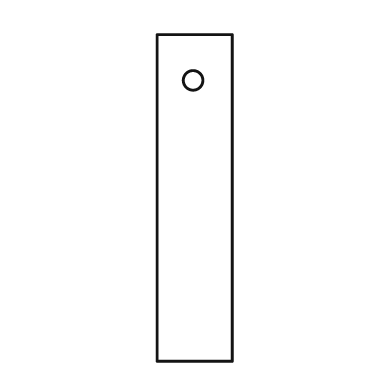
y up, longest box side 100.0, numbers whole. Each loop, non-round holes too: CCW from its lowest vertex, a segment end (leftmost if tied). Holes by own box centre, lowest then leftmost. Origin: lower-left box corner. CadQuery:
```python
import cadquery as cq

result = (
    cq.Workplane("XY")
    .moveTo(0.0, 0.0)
    .lineTo(23.0, 0.0)
    .lineTo(23.0, 100.0)
    .lineTo(0.0, 100.0)
    .close()
    .moveTo(11.0, 86.0)
    .circle(3.0)
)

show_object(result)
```